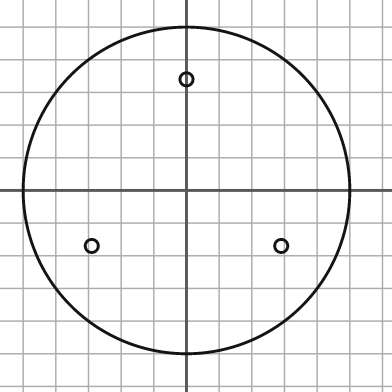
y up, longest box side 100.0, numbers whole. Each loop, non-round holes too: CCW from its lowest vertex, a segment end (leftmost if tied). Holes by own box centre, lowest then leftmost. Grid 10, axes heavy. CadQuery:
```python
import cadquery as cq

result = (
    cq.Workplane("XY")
    .moveTo(0.0, 0.0)
    .circle(50.0)
    .moveTo(-29.0, -17.0)
    .circle(2.0)
    .moveTo(29.0, -17.0)
    .circle(2.0)
    .moveTo(0.0, 34.0)
    .circle(2.0)
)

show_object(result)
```